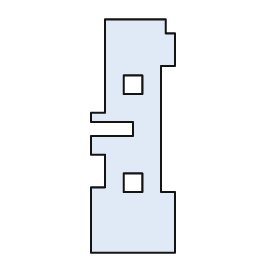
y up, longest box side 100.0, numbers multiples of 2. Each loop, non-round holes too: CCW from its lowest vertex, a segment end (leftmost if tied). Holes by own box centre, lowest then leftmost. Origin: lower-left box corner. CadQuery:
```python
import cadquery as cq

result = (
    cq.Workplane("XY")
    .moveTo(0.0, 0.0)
    .lineTo(36.0, 0.0)
    .lineTo(36.0, 26.0)
    .lineTo(30.0, 26.0)
    .lineTo(30.0, 80.0)
    .lineTo(36.0, 80.0)
    .lineTo(36.0, 94.0)
    .lineTo(32.0, 94.0)
    .lineTo(32.0, 100.0)
    .lineTo(6.0, 100.0)
    .lineTo(6.0, 60.0)
    .lineTo(0.0, 60.0)
    .lineTo(0.0, 56.0)
    .lineTo(18.0, 56.0)
    .lineTo(18.0, 50.0)
    .lineTo(0.0, 50.0)
    .lineTo(0.0, 42.0)
    .lineTo(6.0, 42.0)
    .lineTo(6.0, 28.0)
    .lineTo(0.0, 28.0)
    .close()
    .moveTo(14.0, 26.0)
    .lineTo(22.0, 26.0)
    .lineTo(22.0, 34.0)
    .lineTo(14.0, 34.0)
    .close()
    .moveTo(14.0, 68.0)
    .lineTo(22.0, 68.0)
    .lineTo(22.0, 76.0)
    .lineTo(14.0, 76.0)
    .close()
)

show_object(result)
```